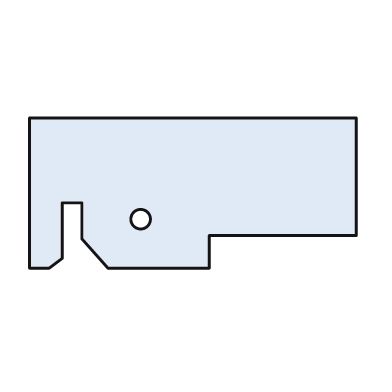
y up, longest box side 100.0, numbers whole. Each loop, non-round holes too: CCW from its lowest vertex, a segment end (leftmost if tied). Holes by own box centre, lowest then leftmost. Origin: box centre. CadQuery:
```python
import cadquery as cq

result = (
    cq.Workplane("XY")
    .moveTo(-50.0, -23.0)
    .lineTo(-44.0, -23.0)
    .lineTo(-40.0, -20.0)
    .lineTo(-40.0, -3.0)
    .lineTo(-34.0, -3.0)
    .lineTo(-34.0, -14.0)
    .lineTo(-26.0, -23.0)
    .lineTo(5.0, -23.0)
    .lineTo(5.0, -13.0)
    .lineTo(50.0, -13.0)
    .lineTo(50.0, 23.0)
    .lineTo(-50.0, 23.0)
    .close()
    .moveTo(-16.0, -8.0)
    .circle(3.0)
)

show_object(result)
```